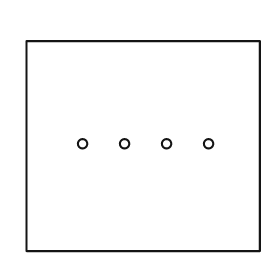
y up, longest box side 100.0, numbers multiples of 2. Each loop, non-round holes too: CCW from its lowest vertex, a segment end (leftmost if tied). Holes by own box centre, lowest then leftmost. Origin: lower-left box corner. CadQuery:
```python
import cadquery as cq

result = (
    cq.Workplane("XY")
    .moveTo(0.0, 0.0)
    .lineTo(100.0, 0.0)
    .lineTo(100.0, 90.0)
    .lineTo(0.0, 90.0)
    .close()
    .moveTo(24.0, 46.0)
    .circle(2.0)
    .moveTo(42.0, 46.0)
    .circle(2.0)
    .moveTo(60.0, 46.0)
    .circle(2.0)
    .moveTo(78.0, 46.0)
    .circle(2.0)
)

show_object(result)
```